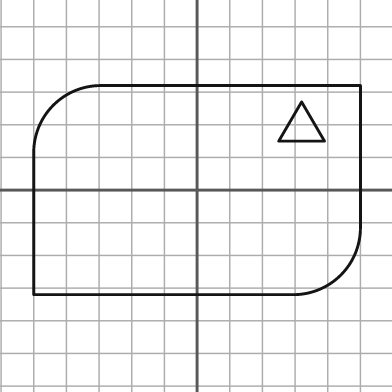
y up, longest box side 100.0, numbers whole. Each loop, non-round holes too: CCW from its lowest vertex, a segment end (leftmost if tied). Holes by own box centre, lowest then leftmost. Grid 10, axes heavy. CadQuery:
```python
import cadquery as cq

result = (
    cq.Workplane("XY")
    .moveTo(-50.0, -32.0)
    .lineTo(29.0, -32.0)
    .threePointArc((44.0, -26.0), (50.0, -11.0))
    .lineTo(50.0, 32.0)
    .lineTo(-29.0, 32.0)
    .threePointArc((-44.0, 26.0), (-50.0, 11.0))
    .close()
    .moveTo(25.0, 15.0)
    .lineTo(39.0, 15.0)
    .lineTo(32.0, 27.0)
    .close()
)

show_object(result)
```